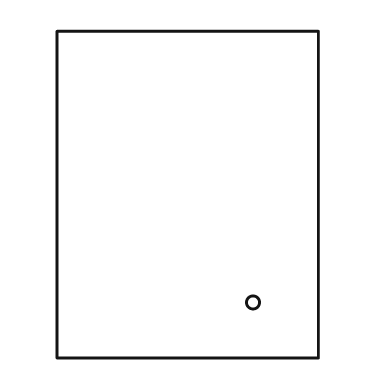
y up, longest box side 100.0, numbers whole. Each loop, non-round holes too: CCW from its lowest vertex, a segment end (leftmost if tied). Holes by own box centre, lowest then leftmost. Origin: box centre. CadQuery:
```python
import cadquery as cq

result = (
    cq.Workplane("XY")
    .moveTo(-40.0, -50.0)
    .lineTo(40.0, -50.0)
    .lineTo(40.0, 50.0)
    .lineTo(-40.0, 50.0)
    .close()
    .moveTo(20.0, -33.0)
    .circle(2.0)
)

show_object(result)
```